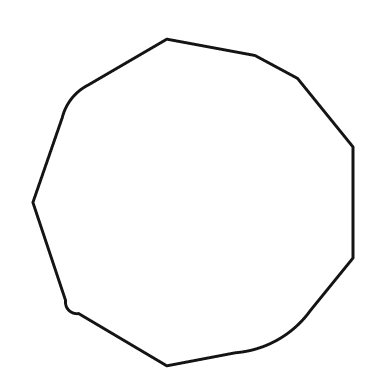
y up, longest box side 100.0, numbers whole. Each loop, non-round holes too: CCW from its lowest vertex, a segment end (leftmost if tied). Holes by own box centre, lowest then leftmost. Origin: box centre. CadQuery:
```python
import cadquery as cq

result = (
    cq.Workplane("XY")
    .moveTo(-8.0, -50.0)
    .lineTo(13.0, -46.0)
    .threePointArc((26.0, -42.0), (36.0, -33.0))
    .lineTo(49.0, -17.0)
    .lineTo(49.0, 17.0)
    .lineTo(32.0, 38.0)
    .lineTo(19.0, 45.0)
    .lineTo(-8.0, 50.0)
    .lineTo(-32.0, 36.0)
    .threePointArc((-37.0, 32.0), (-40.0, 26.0))
    .lineTo(-49.0, 0.0)
    .lineTo(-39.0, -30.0)
    .threePointArc((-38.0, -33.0), (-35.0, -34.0))
    .close()
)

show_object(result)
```